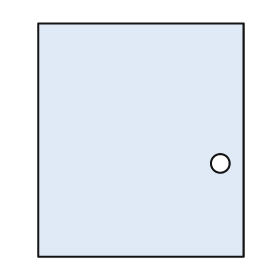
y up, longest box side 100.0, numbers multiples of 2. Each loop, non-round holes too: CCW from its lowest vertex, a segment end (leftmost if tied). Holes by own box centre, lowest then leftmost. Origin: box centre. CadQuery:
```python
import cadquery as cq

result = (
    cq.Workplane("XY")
    .moveTo(-44.0, -50.0)
    .lineTo(44.0, -50.0)
    .lineTo(44.0, 50.0)
    .lineTo(-44.0, 50.0)
    .close()
    .moveTo(34.0, -10.0)
    .circle(4.0)
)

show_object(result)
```